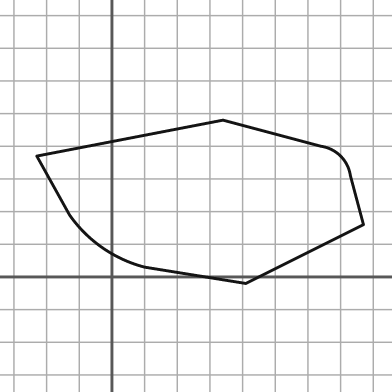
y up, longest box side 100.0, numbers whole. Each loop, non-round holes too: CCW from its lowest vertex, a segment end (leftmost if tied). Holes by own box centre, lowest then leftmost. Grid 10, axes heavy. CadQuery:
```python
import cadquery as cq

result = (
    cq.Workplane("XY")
    .moveTo(41.0, -2.0)
    .lineTo(77.0, 16.0)
    .lineTo(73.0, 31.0)
    .threePointArc((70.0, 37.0), (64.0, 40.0))
    .lineTo(34.0, 48.0)
    .lineTo(-23.0, 37.0)
    .lineTo(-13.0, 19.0)
    .threePointArc((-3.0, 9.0), (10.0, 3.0))
    .close()
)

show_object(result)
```